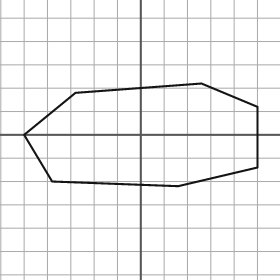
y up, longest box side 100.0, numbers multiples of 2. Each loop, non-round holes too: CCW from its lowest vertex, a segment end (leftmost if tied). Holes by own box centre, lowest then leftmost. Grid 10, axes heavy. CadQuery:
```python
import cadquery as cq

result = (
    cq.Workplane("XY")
    .moveTo(16.0, -22.0)
    .lineTo(50.0, -14.0)
    .lineTo(50.0, 12.0)
    .lineTo(26.0, 22.0)
    .lineTo(-28.0, 18.0)
    .lineTo(-50.0, 0.0)
    .lineTo(-38.0, -20.0)
    .close()
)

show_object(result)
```